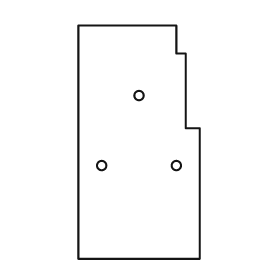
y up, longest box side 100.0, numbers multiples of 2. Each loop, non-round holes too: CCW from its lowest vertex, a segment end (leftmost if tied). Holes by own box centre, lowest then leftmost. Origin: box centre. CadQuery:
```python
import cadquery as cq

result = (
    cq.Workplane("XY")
    .moveTo(-26.0, -50.0)
    .lineTo(26.0, -50.0)
    .lineTo(26.0, 6.0)
    .lineTo(20.0, 6.0)
    .lineTo(20.0, 38.0)
    .lineTo(16.0, 38.0)
    .lineTo(16.0, 50.0)
    .lineTo(-26.0, 50.0)
    .close()
    .moveTo(-16.0, -10.0)
    .circle(2.0)
    .moveTo(16.0, -10.0)
    .circle(2.0)
    .moveTo(0.0, 20.0)
    .circle(2.0)
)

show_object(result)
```